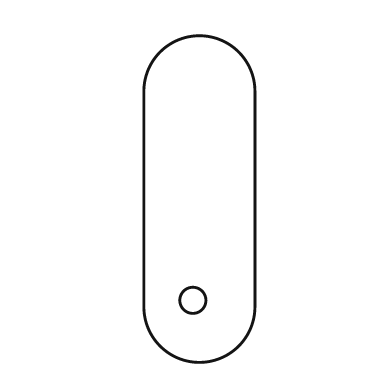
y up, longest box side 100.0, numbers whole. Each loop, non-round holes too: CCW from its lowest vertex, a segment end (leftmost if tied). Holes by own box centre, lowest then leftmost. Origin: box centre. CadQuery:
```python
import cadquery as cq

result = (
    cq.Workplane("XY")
    .moveTo(-17.0, -33.0)
    .threePointArc((0.0, -50.0), (17.0, -33.0))
    .lineTo(17.0, 33.0)
    .threePointArc((0.0, 50.0), (-17.0, 33.0))
    .close()
    .moveTo(-2.0, -31.0)
    .circle(4.0)
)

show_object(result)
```